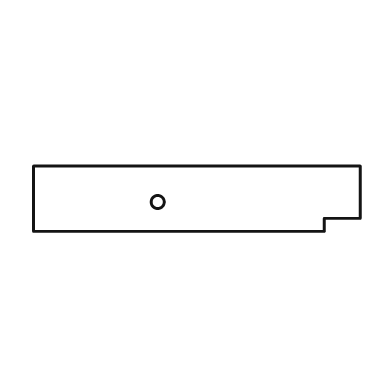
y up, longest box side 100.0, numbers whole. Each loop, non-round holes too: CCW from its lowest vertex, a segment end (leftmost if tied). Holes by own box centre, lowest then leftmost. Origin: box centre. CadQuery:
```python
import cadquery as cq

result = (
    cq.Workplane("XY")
    .moveTo(-50.0, -10.0)
    .lineTo(39.0, -10.0)
    .lineTo(39.0, -6.0)
    .lineTo(50.0, -6.0)
    .lineTo(50.0, 10.0)
    .lineTo(-50.0, 10.0)
    .close()
    .moveTo(-12.0, -1.0)
    .circle(2.0)
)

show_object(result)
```